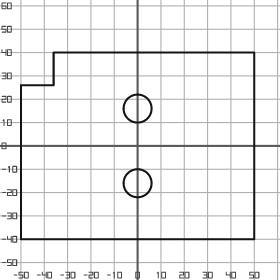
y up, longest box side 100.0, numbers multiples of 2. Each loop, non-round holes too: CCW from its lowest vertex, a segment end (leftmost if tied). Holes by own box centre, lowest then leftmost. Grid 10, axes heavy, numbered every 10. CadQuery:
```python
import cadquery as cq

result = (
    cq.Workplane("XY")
    .moveTo(-50.0, -40.0)
    .lineTo(50.0, -40.0)
    .lineTo(50.0, 40.0)
    .lineTo(-36.0, 40.0)
    .lineTo(-36.0, 26.0)
    .lineTo(-50.0, 26.0)
    .close()
    .moveTo(0.0, -16.0)
    .circle(6.0)
    .moveTo(0.0, 16.0)
    .circle(6.0)
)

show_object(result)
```